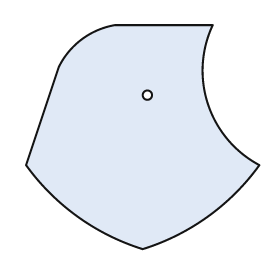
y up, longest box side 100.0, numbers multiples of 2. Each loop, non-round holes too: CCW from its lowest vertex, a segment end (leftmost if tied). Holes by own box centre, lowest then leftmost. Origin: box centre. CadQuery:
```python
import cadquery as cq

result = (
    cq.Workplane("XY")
    .moveTo(0.0, -48.0)
    .threePointArc((28.0, -34.0), (50.0, -12.0))
    .threePointArc((28.0, 14.0), (30.0, 48.0))
    .lineTo(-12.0, 48.0)
    .threePointArc((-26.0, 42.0), (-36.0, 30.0))
    .lineTo(-50.0, -12.0)
    .threePointArc((-28.0, -34.0), (0.0, -48.0))
    .close()
    .moveTo(2.0, 18.0)
    .circle(2.0)
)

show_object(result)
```